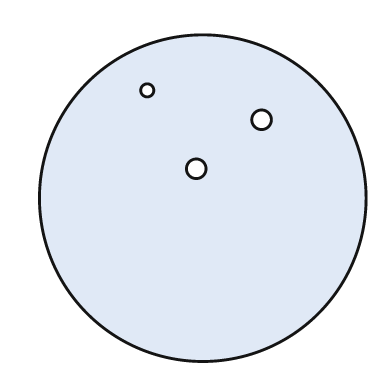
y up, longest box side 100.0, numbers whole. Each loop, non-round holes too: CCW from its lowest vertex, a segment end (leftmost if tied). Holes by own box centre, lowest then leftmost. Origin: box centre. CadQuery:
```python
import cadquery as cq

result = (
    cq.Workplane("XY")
    .moveTo(0.0, 0.0)
    .circle(50.0)
    .moveTo(-2.0, 9.0)
    .circle(3.0)
    .moveTo(18.0, 24.0)
    .circle(3.0)
    .moveTo(-17.0, 33.0)
    .circle(2.0)
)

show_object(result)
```